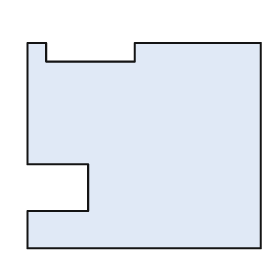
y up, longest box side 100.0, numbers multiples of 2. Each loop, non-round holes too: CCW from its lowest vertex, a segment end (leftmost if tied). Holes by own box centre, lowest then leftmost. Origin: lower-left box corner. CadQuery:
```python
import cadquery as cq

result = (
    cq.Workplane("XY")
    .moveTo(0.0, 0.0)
    .lineTo(100.0, 0.0)
    .lineTo(100.0, 88.0)
    .lineTo(46.0, 88.0)
    .lineTo(46.0, 80.0)
    .lineTo(8.0, 80.0)
    .lineTo(8.0, 88.0)
    .lineTo(0.0, 88.0)
    .lineTo(0.0, 36.0)
    .lineTo(26.0, 36.0)
    .lineTo(26.0, 16.0)
    .lineTo(0.0, 16.0)
    .close()
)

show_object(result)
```